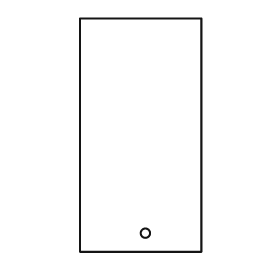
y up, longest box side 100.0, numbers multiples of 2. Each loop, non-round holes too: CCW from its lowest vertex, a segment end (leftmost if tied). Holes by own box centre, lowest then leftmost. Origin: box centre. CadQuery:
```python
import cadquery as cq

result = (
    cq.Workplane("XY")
    .moveTo(-26.0, -50.0)
    .lineTo(26.0, -50.0)
    .lineTo(26.0, 50.0)
    .lineTo(-26.0, 50.0)
    .close()
    .moveTo(2.0, -42.0)
    .circle(2.0)
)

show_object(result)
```